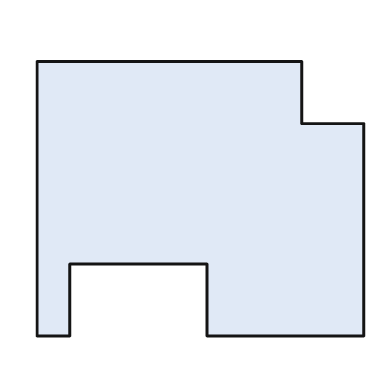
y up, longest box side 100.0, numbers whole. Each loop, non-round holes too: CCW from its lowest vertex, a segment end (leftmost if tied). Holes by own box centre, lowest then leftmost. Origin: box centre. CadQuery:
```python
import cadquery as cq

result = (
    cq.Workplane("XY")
    .moveTo(-50.0, -42.0)
    .lineTo(-40.0, -42.0)
    .lineTo(-40.0, -20.0)
    .lineTo(2.0, -20.0)
    .lineTo(2.0, -42.0)
    .lineTo(50.0, -42.0)
    .lineTo(50.0, 23.0)
    .lineTo(31.0, 23.0)
    .lineTo(31.0, 42.0)
    .lineTo(-50.0, 42.0)
    .close()
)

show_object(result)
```